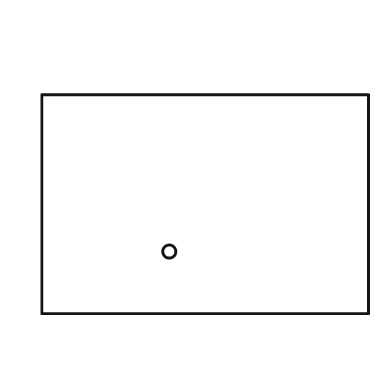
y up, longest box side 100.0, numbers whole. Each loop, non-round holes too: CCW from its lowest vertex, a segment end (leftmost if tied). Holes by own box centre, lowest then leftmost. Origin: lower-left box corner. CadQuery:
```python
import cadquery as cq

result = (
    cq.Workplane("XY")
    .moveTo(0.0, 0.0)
    .lineTo(100.0, 0.0)
    .lineTo(100.0, 67.0)
    .lineTo(0.0, 67.0)
    .close()
    .moveTo(39.0, 19.0)
    .circle(2.0)
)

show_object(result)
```